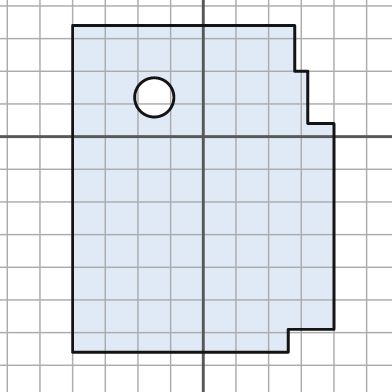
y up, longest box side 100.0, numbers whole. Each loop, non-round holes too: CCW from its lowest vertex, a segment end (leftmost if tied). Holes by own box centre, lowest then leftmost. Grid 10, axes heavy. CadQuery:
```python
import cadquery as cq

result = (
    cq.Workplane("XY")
    .moveTo(-40.0, -66.0)
    .lineTo(26.0, -66.0)
    .lineTo(26.0, -59.0)
    .lineTo(40.0, -59.0)
    .lineTo(40.0, 4.0)
    .lineTo(32.0, 4.0)
    .lineTo(32.0, 20.0)
    .lineTo(28.0, 20.0)
    .lineTo(28.0, 34.0)
    .lineTo(-40.0, 34.0)
    .close()
    .moveTo(-15.0, 12.0)
    .circle(6.0)
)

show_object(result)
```